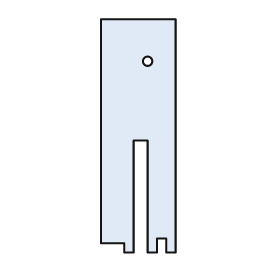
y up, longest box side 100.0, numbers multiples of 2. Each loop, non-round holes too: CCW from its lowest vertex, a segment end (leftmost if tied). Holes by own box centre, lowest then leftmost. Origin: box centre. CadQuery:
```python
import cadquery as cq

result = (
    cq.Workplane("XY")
    .moveTo(-6.0, -50.0)
    .lineTo(-2.0, -50.0)
    .lineTo(-2.0, -2.0)
    .lineTo(4.0, -2.0)
    .lineTo(4.0, -50.0)
    .lineTo(8.0, -50.0)
    .lineTo(8.0, -44.0)
    .lineTo(12.0, -44.0)
    .lineTo(12.0, -50.0)
    .lineTo(16.0, -50.0)
    .lineTo(16.0, 50.0)
    .lineTo(-16.0, 50.0)
    .lineTo(-16.0, -46.0)
    .lineTo(-6.0, -46.0)
    .close()
    .moveTo(4.0, 32.0)
    .circle(2.0)
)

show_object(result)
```